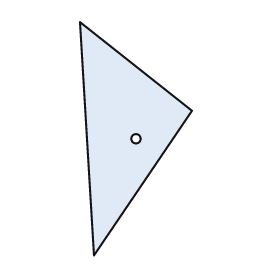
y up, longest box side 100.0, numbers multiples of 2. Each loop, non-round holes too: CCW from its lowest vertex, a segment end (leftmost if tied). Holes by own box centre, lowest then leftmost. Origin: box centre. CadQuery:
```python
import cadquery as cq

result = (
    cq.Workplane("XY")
    .moveTo(-18.0, -50.0)
    .lineTo(24.0, 12.0)
    .lineTo(-24.0, 50.0)
    .close()
    .moveTo(0.0, 0.0)
    .circle(2.0)
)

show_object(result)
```